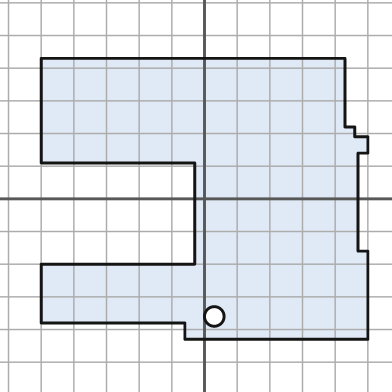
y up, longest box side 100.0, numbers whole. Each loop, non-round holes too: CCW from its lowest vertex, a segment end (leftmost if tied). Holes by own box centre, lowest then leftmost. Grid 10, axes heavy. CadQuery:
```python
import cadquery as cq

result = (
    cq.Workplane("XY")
    .moveTo(-6.0, -43.0)
    .lineTo(50.0, -43.0)
    .lineTo(50.0, -16.0)
    .lineTo(47.0, -16.0)
    .lineTo(47.0, 14.0)
    .lineTo(50.0, 14.0)
    .lineTo(50.0, 19.0)
    .lineTo(46.0, 19.0)
    .lineTo(46.0, 22.0)
    .lineTo(43.0, 22.0)
    .lineTo(43.0, 43.0)
    .lineTo(-50.0, 43.0)
    .lineTo(-50.0, 11.0)
    .lineTo(-3.0, 11.0)
    .lineTo(-3.0, -20.0)
    .lineTo(-50.0, -20.0)
    .lineTo(-50.0, -38.0)
    .lineTo(-6.0, -38.0)
    .close()
    .moveTo(3.0, -36.0)
    .circle(3.0)
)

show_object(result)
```